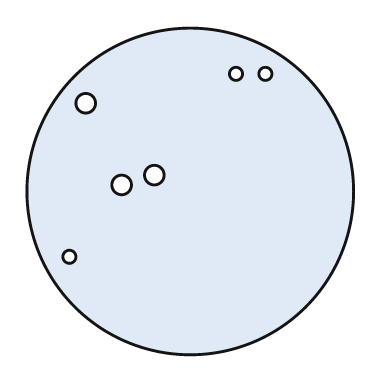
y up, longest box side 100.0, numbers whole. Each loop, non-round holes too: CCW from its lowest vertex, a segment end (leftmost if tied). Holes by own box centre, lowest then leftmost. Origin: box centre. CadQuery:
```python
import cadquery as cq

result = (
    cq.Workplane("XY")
    .moveTo(0.0, 0.0)
    .circle(50.0)
    .moveTo(-37.0, -20.0)
    .circle(2.0)
    .moveTo(-21.0, 2.0)
    .circle(3.0)
    .moveTo(-11.0, 5.0)
    .circle(3.0)
    .moveTo(-32.0, 27.0)
    .circle(3.0)
    .moveTo(14.0, 36.0)
    .circle(2.0)
    .moveTo(23.0, 36.0)
    .circle(2.0)
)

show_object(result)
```